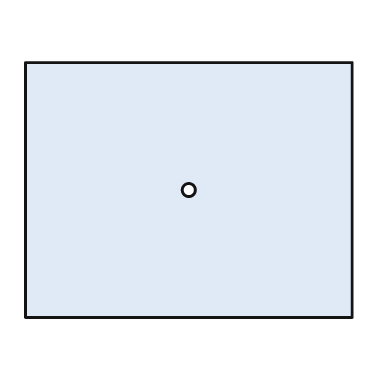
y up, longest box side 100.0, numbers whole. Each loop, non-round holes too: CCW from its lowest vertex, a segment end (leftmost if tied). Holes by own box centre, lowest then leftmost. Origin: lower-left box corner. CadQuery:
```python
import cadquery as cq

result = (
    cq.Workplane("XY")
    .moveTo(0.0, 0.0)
    .lineTo(100.0, 0.0)
    .lineTo(100.0, 78.0)
    .lineTo(0.0, 78.0)
    .close()
    .moveTo(50.0, 39.0)
    .circle(2.0)
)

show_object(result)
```